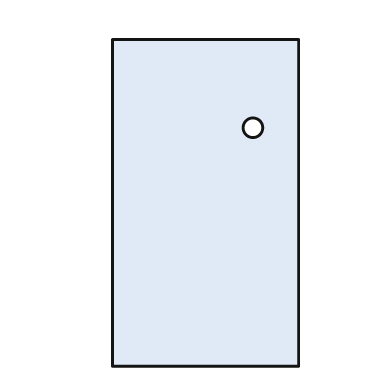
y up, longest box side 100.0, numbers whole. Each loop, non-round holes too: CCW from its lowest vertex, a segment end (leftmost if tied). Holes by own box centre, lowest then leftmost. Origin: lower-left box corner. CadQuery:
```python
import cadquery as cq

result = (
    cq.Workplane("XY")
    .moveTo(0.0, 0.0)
    .lineTo(57.0, 0.0)
    .lineTo(57.0, 100.0)
    .lineTo(0.0, 100.0)
    .close()
    .moveTo(43.0, 73.0)
    .circle(3.0)
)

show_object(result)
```